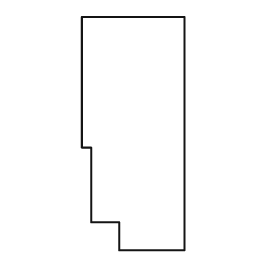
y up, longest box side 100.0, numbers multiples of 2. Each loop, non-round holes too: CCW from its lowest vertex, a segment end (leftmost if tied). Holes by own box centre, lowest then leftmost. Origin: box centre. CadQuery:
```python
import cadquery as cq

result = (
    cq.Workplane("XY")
    .moveTo(-6.0, -50.0)
    .lineTo(22.0, -50.0)
    .lineTo(22.0, 50.0)
    .lineTo(-22.0, 50.0)
    .lineTo(-22.0, -6.0)
    .lineTo(-18.0, -6.0)
    .lineTo(-18.0, -38.0)
    .lineTo(-6.0, -38.0)
    .close()
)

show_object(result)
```